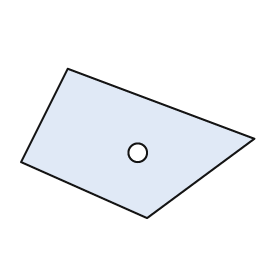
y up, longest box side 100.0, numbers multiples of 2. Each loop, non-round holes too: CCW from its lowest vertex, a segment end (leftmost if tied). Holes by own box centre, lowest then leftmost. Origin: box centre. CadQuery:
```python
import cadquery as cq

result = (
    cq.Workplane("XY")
    .moveTo(4.0, -32.0)
    .lineTo(50.0, 2.0)
    .lineTo(-30.0, 32.0)
    .lineTo(-50.0, -8.0)
    .close()
    .moveTo(0.0, -4.0)
    .circle(4.0)
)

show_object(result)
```